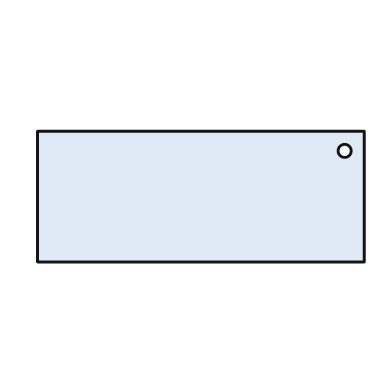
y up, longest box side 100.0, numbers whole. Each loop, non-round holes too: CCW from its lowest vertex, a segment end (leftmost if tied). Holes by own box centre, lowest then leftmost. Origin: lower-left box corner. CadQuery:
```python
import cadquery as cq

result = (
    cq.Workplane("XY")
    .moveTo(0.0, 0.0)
    .lineTo(100.0, 0.0)
    .lineTo(100.0, 40.0)
    .lineTo(0.0, 40.0)
    .close()
    .moveTo(94.0, 34.0)
    .circle(2.0)
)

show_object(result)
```